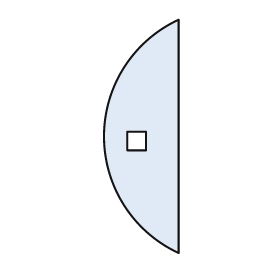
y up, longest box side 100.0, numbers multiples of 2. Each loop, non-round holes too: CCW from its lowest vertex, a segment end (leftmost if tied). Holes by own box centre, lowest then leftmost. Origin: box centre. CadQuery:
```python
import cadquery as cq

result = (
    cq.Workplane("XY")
    .moveTo(16.0, -50.0)
    .lineTo(16.0, 50.0)
    .threePointArc((-16.0, 0.0), (16.0, -50.0))
    .close()
    .moveTo(-6.0, -6.0)
    .lineTo(2.0, -6.0)
    .lineTo(2.0, 2.0)
    .lineTo(-6.0, 2.0)
    .close()
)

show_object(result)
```